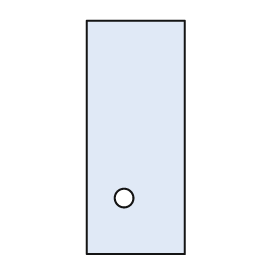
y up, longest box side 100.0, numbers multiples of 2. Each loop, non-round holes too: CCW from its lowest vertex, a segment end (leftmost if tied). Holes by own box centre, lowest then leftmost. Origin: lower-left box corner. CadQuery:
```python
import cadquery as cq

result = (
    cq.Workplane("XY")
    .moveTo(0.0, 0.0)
    .lineTo(42.0, 0.0)
    .lineTo(42.0, 100.0)
    .lineTo(0.0, 100.0)
    .close()
    .moveTo(16.0, 24.0)
    .circle(4.0)
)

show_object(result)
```